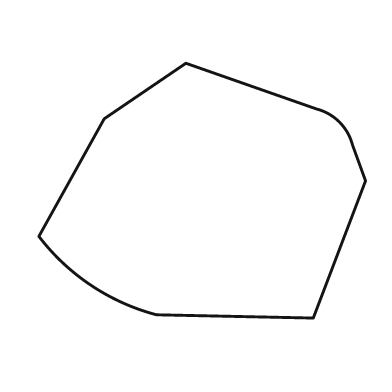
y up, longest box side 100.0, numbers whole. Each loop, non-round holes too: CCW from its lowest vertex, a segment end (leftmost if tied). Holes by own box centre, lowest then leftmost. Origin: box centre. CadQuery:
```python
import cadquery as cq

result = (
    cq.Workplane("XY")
    .moveTo(34.0, -39.0)
    .lineTo(50.0, 3.0)
    .lineTo(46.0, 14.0)
    .threePointArc((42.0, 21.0), (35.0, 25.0))
    .lineTo(-5.0, 39.0)
    .lineTo(-30.0, 22.0)
    .lineTo(-50.0, -14.0)
    .threePointArc((-34.0, -29.0), (-14.0, -38.0))
    .close()
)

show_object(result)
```